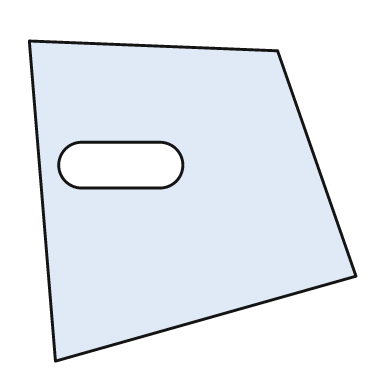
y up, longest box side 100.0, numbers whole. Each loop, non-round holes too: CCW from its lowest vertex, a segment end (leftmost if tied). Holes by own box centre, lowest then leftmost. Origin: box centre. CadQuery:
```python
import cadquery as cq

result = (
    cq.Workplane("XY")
    .moveTo(-42.0, -49.0)
    .lineTo(50.0, -23.0)
    .lineTo(26.0, 46.0)
    .lineTo(-50.0, 49.0)
    .close()
    .moveTo(-34.0, 4.0)
    .lineTo(-10.0, 4.0)
    .threePointArc((-3.0, 11.0), (-10.0, 18.0))
    .lineTo(-34.0, 18.0)
    .threePointArc((-41.0, 11.0), (-34.0, 4.0))
    .close()
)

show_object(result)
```